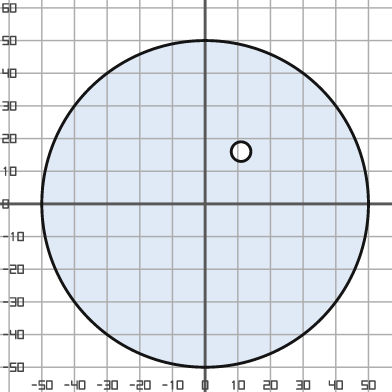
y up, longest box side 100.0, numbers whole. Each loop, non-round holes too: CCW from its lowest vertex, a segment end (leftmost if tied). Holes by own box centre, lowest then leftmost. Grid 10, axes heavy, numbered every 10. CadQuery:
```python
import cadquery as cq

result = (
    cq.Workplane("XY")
    .moveTo(0.0, 0.0)
    .circle(50.0)
    .moveTo(11.0, 16.0)
    .circle(3.0)
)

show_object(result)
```